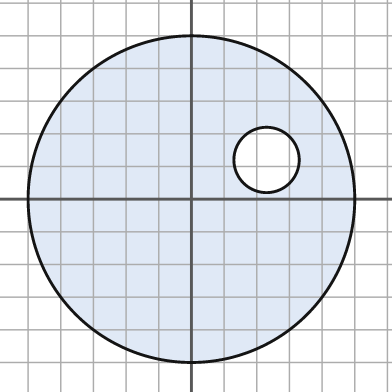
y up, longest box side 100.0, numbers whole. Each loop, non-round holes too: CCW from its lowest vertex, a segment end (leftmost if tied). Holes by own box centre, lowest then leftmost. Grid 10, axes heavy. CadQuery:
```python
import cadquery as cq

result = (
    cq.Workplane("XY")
    .moveTo(0.0, 0.0)
    .circle(50.0)
    .moveTo(23.0, 12.0)
    .circle(10.0)
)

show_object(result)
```